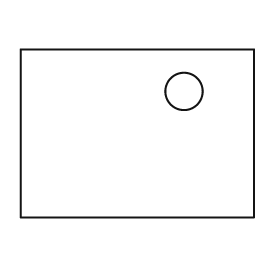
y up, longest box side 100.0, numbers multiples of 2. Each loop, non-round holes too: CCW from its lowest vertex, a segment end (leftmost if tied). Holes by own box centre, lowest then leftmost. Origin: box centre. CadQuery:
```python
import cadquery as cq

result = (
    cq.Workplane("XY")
    .moveTo(-50.0, -36.0)
    .lineTo(50.0, -36.0)
    .lineTo(50.0, 36.0)
    .lineTo(-50.0, 36.0)
    .close()
    .moveTo(20.0, 18.0)
    .circle(8.0)
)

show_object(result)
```